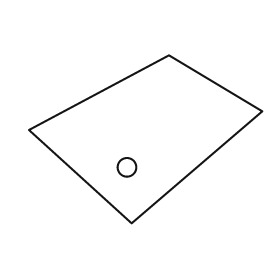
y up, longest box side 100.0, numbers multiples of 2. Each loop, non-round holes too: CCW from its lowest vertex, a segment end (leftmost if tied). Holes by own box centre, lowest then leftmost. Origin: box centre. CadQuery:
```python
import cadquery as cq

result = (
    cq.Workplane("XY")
    .moveTo(-6.0, -36.0)
    .lineTo(50.0, 12.0)
    .lineTo(10.0, 36.0)
    .lineTo(-50.0, 4.0)
    .close()
    .moveTo(-8.0, -12.0)
    .circle(4.0)
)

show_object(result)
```